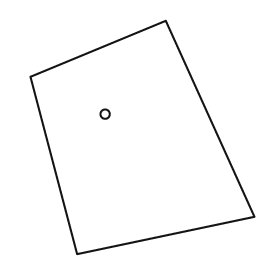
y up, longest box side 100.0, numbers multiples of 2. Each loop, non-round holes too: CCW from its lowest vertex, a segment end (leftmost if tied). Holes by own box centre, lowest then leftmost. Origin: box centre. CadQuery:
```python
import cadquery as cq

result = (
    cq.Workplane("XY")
    .moveTo(-28.0, -50.0)
    .lineTo(48.0, -34.0)
    .lineTo(10.0, 50.0)
    .lineTo(-48.0, 26.0)
    .close()
    .moveTo(-16.0, 10.0)
    .circle(2.0)
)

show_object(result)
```